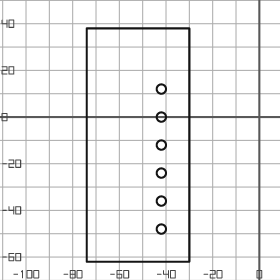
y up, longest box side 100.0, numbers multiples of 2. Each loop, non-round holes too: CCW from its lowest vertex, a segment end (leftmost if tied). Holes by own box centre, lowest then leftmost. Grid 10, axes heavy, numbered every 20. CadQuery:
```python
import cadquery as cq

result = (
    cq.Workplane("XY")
    .moveTo(-74.0, -62.0)
    .lineTo(-30.0, -62.0)
    .lineTo(-30.0, 38.0)
    .lineTo(-74.0, 38.0)
    .close()
    .moveTo(-42.0, -48.0)
    .circle(2.0)
    .moveTo(-42.0, -36.0)
    .circle(2.0)
    .moveTo(-42.0, -24.0)
    .circle(2.0)
    .moveTo(-42.0, -12.0)
    .circle(2.0)
    .moveTo(-42.0, 0.0)
    .circle(2.0)
    .moveTo(-42.0, 12.0)
    .circle(2.0)
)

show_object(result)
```